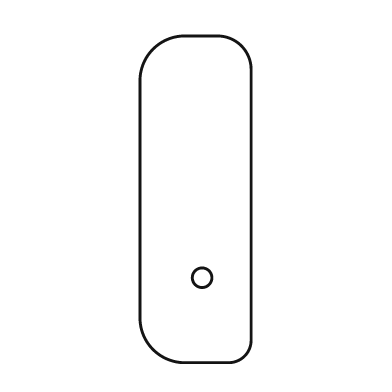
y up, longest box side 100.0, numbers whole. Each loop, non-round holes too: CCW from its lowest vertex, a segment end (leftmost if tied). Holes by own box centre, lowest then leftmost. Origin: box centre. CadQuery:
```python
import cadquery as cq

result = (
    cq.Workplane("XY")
    .moveTo(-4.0, -50.0)
    .lineTo(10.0, -50.0)
    .threePointArc((15.0, -48.0), (17.0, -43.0))
    .lineTo(17.0, 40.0)
    .threePointArc((14.0, 47.0), (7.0, 50.0))
    .lineTo(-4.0, 50.0)
    .threePointArc((-13.0, 46.0), (-17.0, 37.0))
    .lineTo(-17.0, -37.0)
    .threePointArc((-13.0, -46.0), (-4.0, -50.0))
    .close()
    .moveTo(2.0, -24.0)
    .circle(3.0)
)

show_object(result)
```